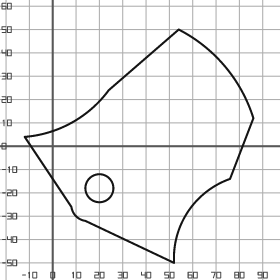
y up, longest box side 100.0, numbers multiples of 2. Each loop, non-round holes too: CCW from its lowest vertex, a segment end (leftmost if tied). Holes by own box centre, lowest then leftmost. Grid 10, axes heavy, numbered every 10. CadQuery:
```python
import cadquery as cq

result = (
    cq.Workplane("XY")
    .moveTo(52.0, -50.0)
    .threePointArc((58.0, -28.0), (76.0, -14.0))
    .lineTo(86.0, 12.0)
    .threePointArc((74.0, 34.0), (54.0, 50.0))
    .lineTo(24.0, 24.0)
    .threePointArc((8.0, 10.0), (-12.0, 4.0))
    .lineTo(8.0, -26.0)
    .threePointArc((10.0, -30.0), (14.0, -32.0))
    .close()
    .moveTo(20.0, -18.0)
    .circle(6.0)
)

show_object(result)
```